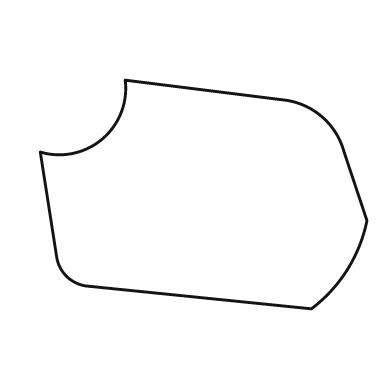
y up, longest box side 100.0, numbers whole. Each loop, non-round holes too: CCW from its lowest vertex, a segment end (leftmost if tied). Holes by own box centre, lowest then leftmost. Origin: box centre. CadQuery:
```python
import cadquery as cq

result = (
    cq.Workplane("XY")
    .moveTo(33.0, -35.0)
    .threePointArc((44.0, -23.0), (50.0, -8.0))
    .lineTo(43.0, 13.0)
    .threePointArc((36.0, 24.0), (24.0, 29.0))
    .lineTo(-24.0, 35.0)
    .threePointArc((-31.0, 17.0), (-50.0, 13.0))
    .lineTo(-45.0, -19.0)
    .threePointArc((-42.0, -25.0), (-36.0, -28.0))
    .close()
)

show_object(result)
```